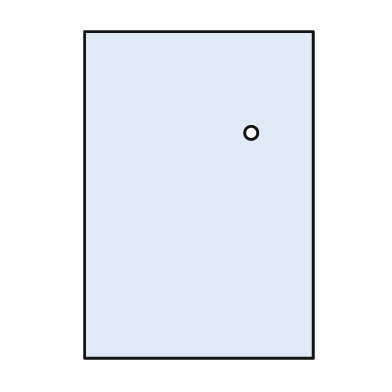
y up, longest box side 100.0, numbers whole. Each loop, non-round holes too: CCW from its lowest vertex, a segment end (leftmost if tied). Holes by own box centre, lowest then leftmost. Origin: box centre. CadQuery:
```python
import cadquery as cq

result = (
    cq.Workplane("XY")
    .moveTo(-35.0, -50.0)
    .lineTo(35.0, -50.0)
    .lineTo(35.0, 50.0)
    .lineTo(-35.0, 50.0)
    .close()
    .moveTo(16.0, 19.0)
    .circle(2.0)
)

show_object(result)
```